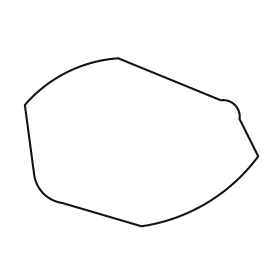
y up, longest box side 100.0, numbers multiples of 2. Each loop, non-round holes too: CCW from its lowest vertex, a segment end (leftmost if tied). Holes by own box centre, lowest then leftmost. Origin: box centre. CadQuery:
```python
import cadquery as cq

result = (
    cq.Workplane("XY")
    .moveTo(0.0, -36.0)
    .threePointArc((28.0, -26.0), (50.0, -6.0))
    .lineTo(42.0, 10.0)
    .threePointArc((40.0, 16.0), (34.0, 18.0))
    .lineTo(-10.0, 36.0)
    .threePointArc((-32.0, 30.0), (-50.0, 16.0))
    .lineTo(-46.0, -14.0)
    .threePointArc((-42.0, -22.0), (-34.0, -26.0))
    .close()
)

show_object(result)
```